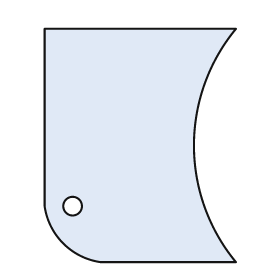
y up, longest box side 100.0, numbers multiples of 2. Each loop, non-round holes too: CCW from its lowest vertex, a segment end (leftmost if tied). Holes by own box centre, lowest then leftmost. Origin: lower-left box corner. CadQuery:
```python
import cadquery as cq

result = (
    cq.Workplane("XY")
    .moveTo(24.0, 0.0)
    .lineTo(82.0, 0.0)
    .threePointArc((64.0, 50.0), (82.0, 100.0))
    .lineTo(0.0, 100.0)
    .lineTo(0.0, 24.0)
    .threePointArc((8.0, 8.0), (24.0, 0.0))
    .close()
    .moveTo(12.0, 24.0)
    .circle(4.0)
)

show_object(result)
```